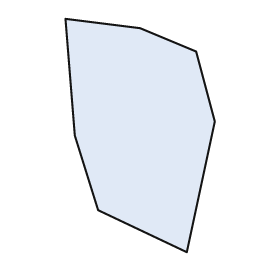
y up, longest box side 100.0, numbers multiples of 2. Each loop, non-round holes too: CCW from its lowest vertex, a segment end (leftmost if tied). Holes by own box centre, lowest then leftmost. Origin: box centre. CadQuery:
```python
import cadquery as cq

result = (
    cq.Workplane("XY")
    .moveTo(20.0, -50.0)
    .lineTo(32.0, 6.0)
    .lineTo(24.0, 36.0)
    .lineTo(0.0, 46.0)
    .lineTo(-32.0, 50.0)
    .lineTo(-28.0, 0.0)
    .lineTo(-18.0, -32.0)
    .close()
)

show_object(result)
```